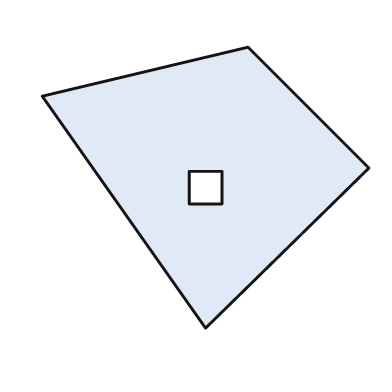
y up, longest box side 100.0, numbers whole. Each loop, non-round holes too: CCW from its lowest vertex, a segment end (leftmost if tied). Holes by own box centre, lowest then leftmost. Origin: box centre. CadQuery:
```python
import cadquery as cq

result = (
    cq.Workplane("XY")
    .moveTo(0.0, -43.0)
    .lineTo(50.0, 6.0)
    .lineTo(13.0, 43.0)
    .lineTo(-50.0, 28.0)
    .close()
    .moveTo(-5.0, -5.0)
    .lineTo(5.0, -5.0)
    .lineTo(5.0, 5.0)
    .lineTo(-5.0, 5.0)
    .close()
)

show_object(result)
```